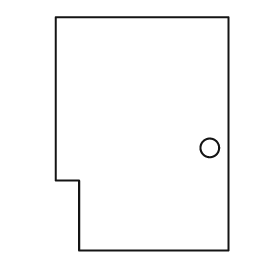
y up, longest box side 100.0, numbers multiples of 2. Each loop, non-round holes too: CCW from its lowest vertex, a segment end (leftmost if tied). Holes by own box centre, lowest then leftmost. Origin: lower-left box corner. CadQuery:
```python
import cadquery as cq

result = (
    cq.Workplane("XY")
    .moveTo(10.0, 0.0)
    .lineTo(74.0, 0.0)
    .lineTo(74.0, 100.0)
    .lineTo(0.0, 100.0)
    .lineTo(0.0, 30.0)
    .lineTo(10.0, 30.0)
    .close()
    .moveTo(66.0, 44.0)
    .circle(4.0)
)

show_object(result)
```